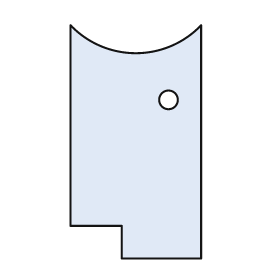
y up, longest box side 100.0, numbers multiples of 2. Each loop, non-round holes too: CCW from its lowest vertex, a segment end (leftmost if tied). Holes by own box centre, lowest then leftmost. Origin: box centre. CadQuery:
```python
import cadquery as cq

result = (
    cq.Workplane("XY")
    .moveTo(-6.0, -50.0)
    .lineTo(28.0, -50.0)
    .lineTo(28.0, 50.0)
    .threePointArc((0.0, 38.0), (-28.0, 50.0))
    .lineTo(-28.0, -36.0)
    .lineTo(-6.0, -36.0)
    .close()
    .moveTo(14.0, 18.0)
    .circle(4.0)
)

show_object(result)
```